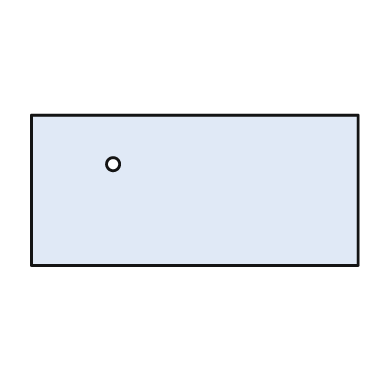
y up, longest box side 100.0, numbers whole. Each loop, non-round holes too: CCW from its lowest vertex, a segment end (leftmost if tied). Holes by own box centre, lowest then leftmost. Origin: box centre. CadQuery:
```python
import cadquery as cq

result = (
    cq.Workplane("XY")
    .moveTo(-50.0, -23.0)
    .lineTo(50.0, -23.0)
    .lineTo(50.0, 23.0)
    .lineTo(-50.0, 23.0)
    .close()
    .moveTo(-25.0, 8.0)
    .circle(2.0)
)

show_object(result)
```